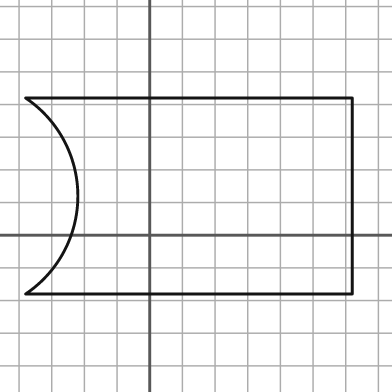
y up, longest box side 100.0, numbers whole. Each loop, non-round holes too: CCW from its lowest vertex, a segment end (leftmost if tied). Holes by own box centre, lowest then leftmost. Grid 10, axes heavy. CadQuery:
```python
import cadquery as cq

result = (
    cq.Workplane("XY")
    .moveTo(-38.0, -18.0)
    .lineTo(62.0, -18.0)
    .lineTo(62.0, 42.0)
    .lineTo(-38.0, 42.0)
    .threePointArc((-22.0, 12.0), (-38.0, -18.0))
    .close()
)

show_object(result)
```